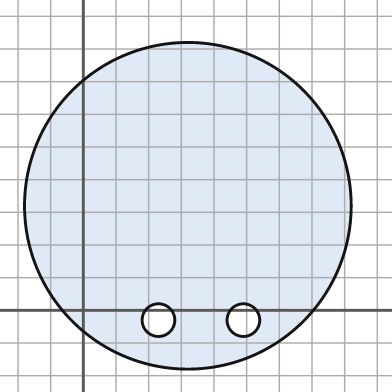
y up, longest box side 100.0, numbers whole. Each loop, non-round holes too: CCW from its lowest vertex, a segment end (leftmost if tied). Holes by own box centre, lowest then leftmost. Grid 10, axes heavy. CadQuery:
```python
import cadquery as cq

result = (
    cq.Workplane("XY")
    .moveTo(32.0, 32.0)
    .circle(50.0)
    .moveTo(23.0, -3.0)
    .circle(5.0)
    .moveTo(49.0, -3.0)
    .circle(5.0)
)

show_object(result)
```